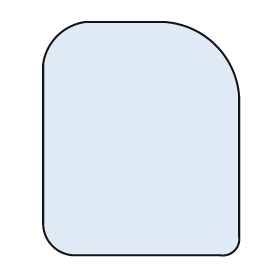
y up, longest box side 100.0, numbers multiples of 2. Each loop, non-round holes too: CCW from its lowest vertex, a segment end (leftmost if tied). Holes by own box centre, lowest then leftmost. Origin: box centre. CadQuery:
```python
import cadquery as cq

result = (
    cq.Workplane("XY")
    .moveTo(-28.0, -50.0)
    .lineTo(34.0, -50.0)
    .threePointArc((40.0, -48.0), (42.0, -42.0))
    .lineTo(42.0, 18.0)
    .threePointArc((32.0, 40.0), (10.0, 50.0))
    .lineTo(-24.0, 50.0)
    .threePointArc((-36.0, 44.0), (-42.0, 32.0))
    .lineTo(-42.0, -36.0)
    .threePointArc((-38.0, -46.0), (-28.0, -50.0))
    .close()
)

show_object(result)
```